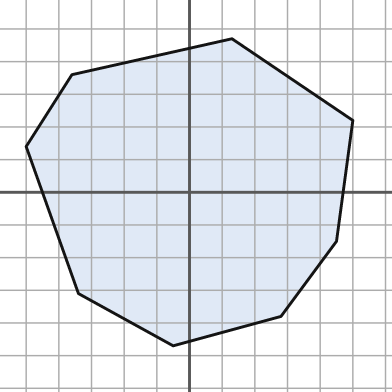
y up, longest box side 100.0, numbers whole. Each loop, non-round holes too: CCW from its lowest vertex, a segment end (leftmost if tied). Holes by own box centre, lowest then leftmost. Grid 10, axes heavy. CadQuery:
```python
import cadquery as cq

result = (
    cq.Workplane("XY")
    .moveTo(-5.0, -47.0)
    .lineTo(28.0, -38.0)
    .lineTo(45.0, -15.0)
    .lineTo(50.0, 22.0)
    .lineTo(13.0, 47.0)
    .lineTo(-36.0, 36.0)
    .lineTo(-50.0, 14.0)
    .lineTo(-34.0, -31.0)
    .close()
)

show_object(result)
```